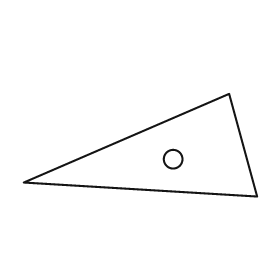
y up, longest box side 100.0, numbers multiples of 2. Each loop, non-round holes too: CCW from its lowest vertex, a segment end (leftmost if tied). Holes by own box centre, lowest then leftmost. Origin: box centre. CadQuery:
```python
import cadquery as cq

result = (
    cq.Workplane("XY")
    .moveTo(50.0, -22.0)
    .lineTo(38.0, 22.0)
    .lineTo(-50.0, -16.0)
    .close()
    .moveTo(14.0, -6.0)
    .circle(4.0)
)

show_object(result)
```